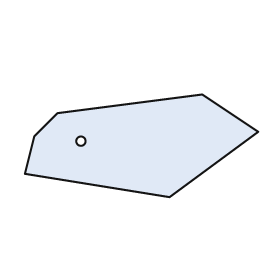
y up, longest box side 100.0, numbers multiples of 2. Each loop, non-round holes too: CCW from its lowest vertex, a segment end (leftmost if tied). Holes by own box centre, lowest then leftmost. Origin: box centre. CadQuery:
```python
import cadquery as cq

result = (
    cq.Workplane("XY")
    .moveTo(12.0, -22.0)
    .lineTo(50.0, 6.0)
    .lineTo(26.0, 22.0)
    .lineTo(-36.0, 14.0)
    .lineTo(-46.0, 4.0)
    .lineTo(-50.0, -12.0)
    .close()
    .moveTo(-26.0, 2.0)
    .circle(2.0)
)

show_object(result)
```